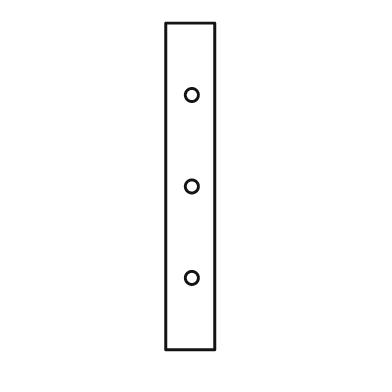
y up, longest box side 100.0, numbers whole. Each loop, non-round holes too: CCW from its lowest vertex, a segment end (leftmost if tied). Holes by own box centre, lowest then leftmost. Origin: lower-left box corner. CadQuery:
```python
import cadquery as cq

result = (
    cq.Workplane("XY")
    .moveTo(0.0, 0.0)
    .lineTo(15.0, 0.0)
    .lineTo(15.0, 100.0)
    .lineTo(0.0, 100.0)
    .close()
    .moveTo(8.0, 22.0)
    .circle(2.0)
    .moveTo(8.0, 50.0)
    .circle(2.0)
    .moveTo(8.0, 78.0)
    .circle(2.0)
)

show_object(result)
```